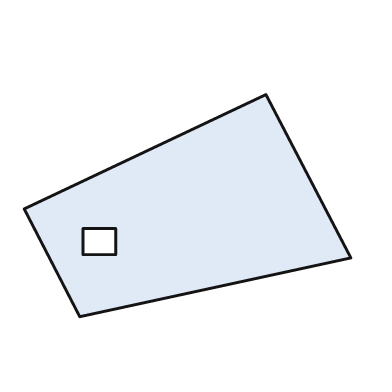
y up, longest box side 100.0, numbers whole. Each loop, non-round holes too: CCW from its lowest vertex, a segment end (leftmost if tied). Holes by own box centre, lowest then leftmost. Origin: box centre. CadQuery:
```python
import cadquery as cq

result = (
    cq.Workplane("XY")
    .moveTo(-33.0, -34.0)
    .lineTo(50.0, -16.0)
    .lineTo(24.0, 34.0)
    .lineTo(-50.0, -1.0)
    .close()
    .moveTo(-32.0, -15.0)
    .lineTo(-22.0, -15.0)
    .lineTo(-22.0, -7.0)
    .lineTo(-32.0, -7.0)
    .close()
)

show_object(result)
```